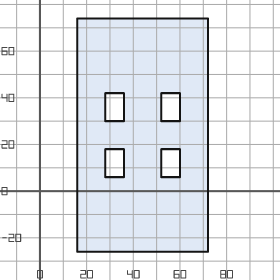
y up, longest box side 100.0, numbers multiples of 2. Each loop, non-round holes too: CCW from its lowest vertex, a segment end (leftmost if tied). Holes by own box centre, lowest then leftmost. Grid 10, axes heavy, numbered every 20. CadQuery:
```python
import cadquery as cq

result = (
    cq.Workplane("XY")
    .moveTo(16.0, -26.0)
    .lineTo(72.0, -26.0)
    .lineTo(72.0, 74.0)
    .lineTo(16.0, 74.0)
    .close()
    .moveTo(28.0, 6.0)
    .lineTo(36.0, 6.0)
    .lineTo(36.0, 18.0)
    .lineTo(28.0, 18.0)
    .close()
    .moveTo(52.0, 6.0)
    .lineTo(60.0, 6.0)
    .lineTo(60.0, 18.0)
    .lineTo(52.0, 18.0)
    .close()
    .moveTo(28.0, 30.0)
    .lineTo(36.0, 30.0)
    .lineTo(36.0, 42.0)
    .lineTo(28.0, 42.0)
    .close()
    .moveTo(52.0, 30.0)
    .lineTo(60.0, 30.0)
    .lineTo(60.0, 42.0)
    .lineTo(52.0, 42.0)
    .close()
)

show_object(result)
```